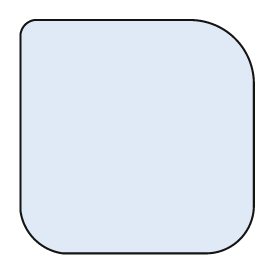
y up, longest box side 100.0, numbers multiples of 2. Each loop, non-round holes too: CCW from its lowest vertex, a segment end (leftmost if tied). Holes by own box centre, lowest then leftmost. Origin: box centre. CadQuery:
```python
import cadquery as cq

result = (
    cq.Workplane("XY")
    .moveTo(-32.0, -50.0)
    .lineTo(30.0, -50.0)
    .threePointArc((44.0, -44.0), (50.0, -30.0))
    .lineTo(50.0, 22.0)
    .threePointArc((42.0, 42.0), (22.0, 50.0))
    .lineTo(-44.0, 50.0)
    .threePointArc((-48.0, 48.0), (-50.0, 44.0))
    .lineTo(-50.0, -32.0)
    .threePointArc((-44.0, -44.0), (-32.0, -50.0))
    .close()
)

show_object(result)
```